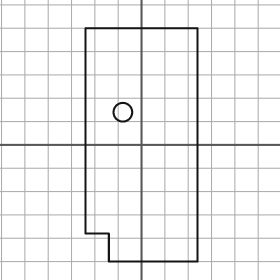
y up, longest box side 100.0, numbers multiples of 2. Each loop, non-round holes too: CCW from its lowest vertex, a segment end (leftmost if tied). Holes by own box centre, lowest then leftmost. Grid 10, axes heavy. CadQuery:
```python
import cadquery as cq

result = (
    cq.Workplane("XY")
    .moveTo(-14.0, -50.0)
    .lineTo(24.0, -50.0)
    .lineTo(24.0, 50.0)
    .lineTo(-24.0, 50.0)
    .lineTo(-24.0, -38.0)
    .lineTo(-14.0, -38.0)
    .close()
    .moveTo(-8.0, 14.0)
    .circle(4.0)
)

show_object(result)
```